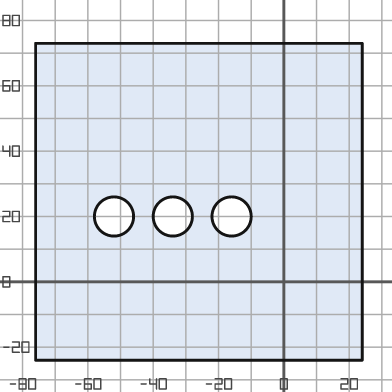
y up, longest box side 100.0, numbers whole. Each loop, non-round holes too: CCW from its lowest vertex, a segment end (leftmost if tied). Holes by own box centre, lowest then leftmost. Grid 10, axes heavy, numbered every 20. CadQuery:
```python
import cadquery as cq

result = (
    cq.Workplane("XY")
    .moveTo(-76.0, -24.0)
    .lineTo(24.0, -24.0)
    .lineTo(24.0, 73.0)
    .lineTo(-76.0, 73.0)
    .close()
    .moveTo(-52.0, 20.0)
    .circle(6.0)
    .moveTo(-34.0, 20.0)
    .circle(6.0)
    .moveTo(-16.0, 20.0)
    .circle(6.0)
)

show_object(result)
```